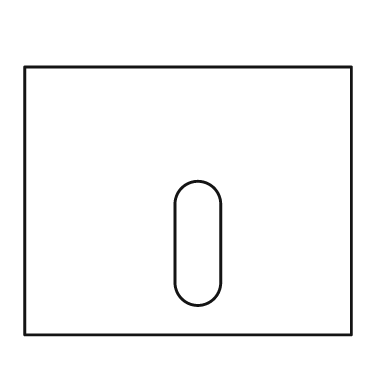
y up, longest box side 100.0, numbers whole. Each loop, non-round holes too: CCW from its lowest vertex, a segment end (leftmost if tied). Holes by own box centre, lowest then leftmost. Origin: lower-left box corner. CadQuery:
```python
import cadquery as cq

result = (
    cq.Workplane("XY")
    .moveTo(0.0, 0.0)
    .lineTo(100.0, 0.0)
    .lineTo(100.0, 82.0)
    .lineTo(0.0, 82.0)
    .close()
    .moveTo(46.0, 16.0)
    .threePointArc((53.0, 9.0), (60.0, 16.0))
    .lineTo(60.0, 40.0)
    .threePointArc((53.0, 47.0), (46.0, 40.0))
    .close()
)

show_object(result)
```